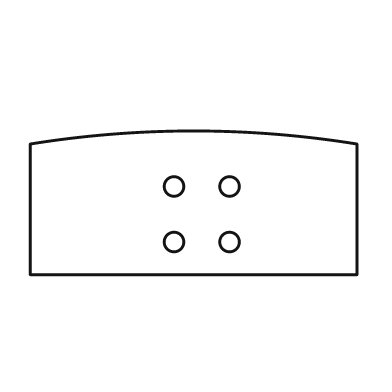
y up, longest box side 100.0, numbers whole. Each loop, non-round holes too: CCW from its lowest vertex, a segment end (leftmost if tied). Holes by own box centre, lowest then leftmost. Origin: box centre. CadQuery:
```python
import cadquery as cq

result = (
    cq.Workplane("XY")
    .moveTo(-50.0, -22.0)
    .lineTo(50.0, -22.0)
    .lineTo(50.0, 18.0)
    .threePointArc((0.0, 22.0), (-50.0, 18.0))
    .close()
    .moveTo(-6.0, -12.0)
    .circle(3.0)
    .moveTo(11.0, -12.0)
    .circle(3.0)
    .moveTo(-6.0, 5.0)
    .circle(3.0)
    .moveTo(11.0, 5.0)
    .circle(3.0)
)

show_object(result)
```